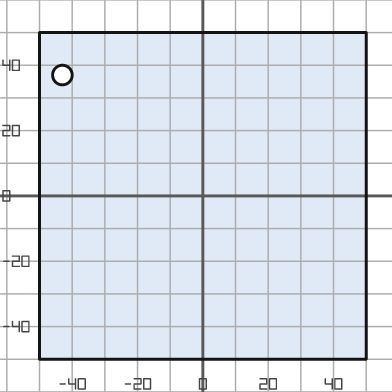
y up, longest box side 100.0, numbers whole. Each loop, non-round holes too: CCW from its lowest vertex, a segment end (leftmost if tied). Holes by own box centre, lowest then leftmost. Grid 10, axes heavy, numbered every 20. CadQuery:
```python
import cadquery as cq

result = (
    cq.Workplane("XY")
    .moveTo(-50.0, -50.0)
    .lineTo(50.0, -50.0)
    .lineTo(50.0, 50.0)
    .lineTo(-50.0, 50.0)
    .close()
    .moveTo(-43.0, 37.0)
    .circle(3.0)
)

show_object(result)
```